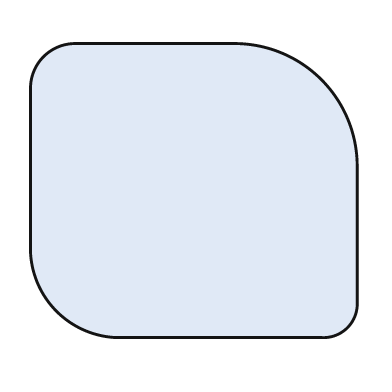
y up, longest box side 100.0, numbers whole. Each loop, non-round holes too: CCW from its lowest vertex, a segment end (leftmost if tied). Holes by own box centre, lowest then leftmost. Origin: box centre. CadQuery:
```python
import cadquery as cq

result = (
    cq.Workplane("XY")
    .moveTo(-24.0, -45.0)
    .lineTo(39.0, -45.0)
    .threePointArc((47.0, -42.0), (50.0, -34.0))
    .lineTo(50.0, 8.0)
    .threePointArc((39.0, 34.0), (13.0, 45.0))
    .lineTo(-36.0, 45.0)
    .threePointArc((-46.0, 41.0), (-50.0, 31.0))
    .lineTo(-50.0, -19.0)
    .threePointArc((-42.0, -37.0), (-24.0, -45.0))
    .close()
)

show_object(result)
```